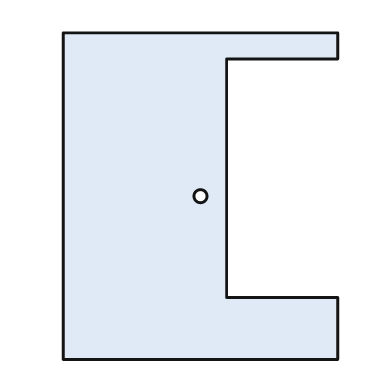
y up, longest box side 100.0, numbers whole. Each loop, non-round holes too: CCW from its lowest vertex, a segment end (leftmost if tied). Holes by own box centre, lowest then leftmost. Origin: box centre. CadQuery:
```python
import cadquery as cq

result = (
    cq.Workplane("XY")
    .moveTo(-42.0, -50.0)
    .lineTo(42.0, -50.0)
    .lineTo(42.0, -31.0)
    .lineTo(8.0, -31.0)
    .lineTo(8.0, 42.0)
    .lineTo(42.0, 42.0)
    .lineTo(42.0, 50.0)
    .lineTo(-42.0, 50.0)
    .close()
    .moveTo(0.0, 0.0)
    .circle(2.0)
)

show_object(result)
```